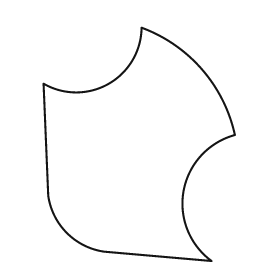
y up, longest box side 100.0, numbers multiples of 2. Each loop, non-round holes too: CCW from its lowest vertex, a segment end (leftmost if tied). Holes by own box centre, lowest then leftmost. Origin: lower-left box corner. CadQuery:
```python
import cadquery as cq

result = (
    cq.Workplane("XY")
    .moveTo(72.0, 0.0)
    .threePointArc((60.0, 30.0), (82.0, 54.0))
    .threePointArc((68.0, 82.0), (42.0, 100.0))
    .threePointArc((28.0, 76.0), (0.0, 76.0))
    .lineTo(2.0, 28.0)
    .threePointArc((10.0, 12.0), (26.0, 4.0))
    .close()
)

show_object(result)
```